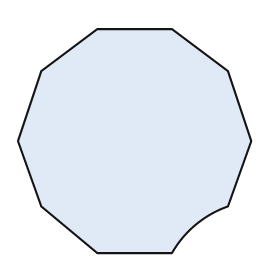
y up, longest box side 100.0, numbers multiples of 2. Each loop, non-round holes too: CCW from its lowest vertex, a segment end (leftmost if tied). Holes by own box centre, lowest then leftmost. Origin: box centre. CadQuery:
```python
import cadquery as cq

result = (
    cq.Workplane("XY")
    .moveTo(-16.0, -48.0)
    .lineTo(16.0, -48.0)
    .threePointArc((26.0, -36.0), (40.0, -28.0))
    .lineTo(50.0, 0.0)
    .lineTo(40.0, 30.0)
    .lineTo(16.0, 48.0)
    .lineTo(-16.0, 48.0)
    .lineTo(-40.0, 30.0)
    .lineTo(-50.0, 0.0)
    .lineTo(-40.0, -28.0)
    .close()
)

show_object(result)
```